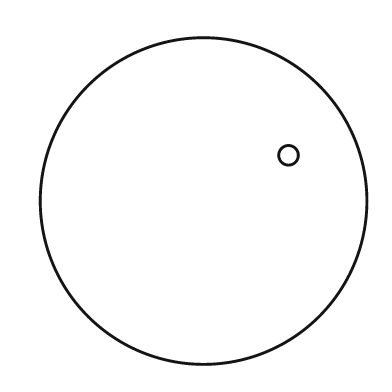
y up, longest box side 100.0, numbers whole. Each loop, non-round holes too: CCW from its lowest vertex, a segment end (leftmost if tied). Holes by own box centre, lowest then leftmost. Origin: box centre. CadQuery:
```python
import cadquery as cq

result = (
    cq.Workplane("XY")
    .moveTo(0.0, 0.0)
    .circle(50.0)
    .moveTo(26.0, 14.0)
    .circle(3.0)
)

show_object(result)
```